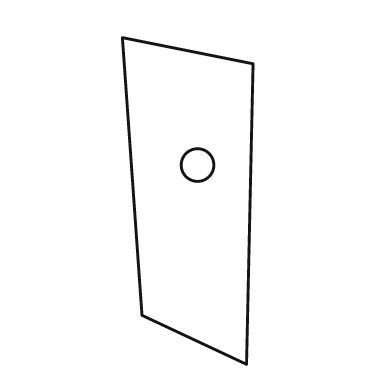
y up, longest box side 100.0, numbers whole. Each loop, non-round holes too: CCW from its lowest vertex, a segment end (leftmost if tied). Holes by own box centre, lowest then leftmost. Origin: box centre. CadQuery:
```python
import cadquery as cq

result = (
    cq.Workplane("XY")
    .moveTo(18.0, -50.0)
    .lineTo(20.0, 42.0)
    .lineTo(-20.0, 50.0)
    .lineTo(-14.0, -35.0)
    .close()
    .moveTo(3.0, 11.0)
    .circle(5.0)
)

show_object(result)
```